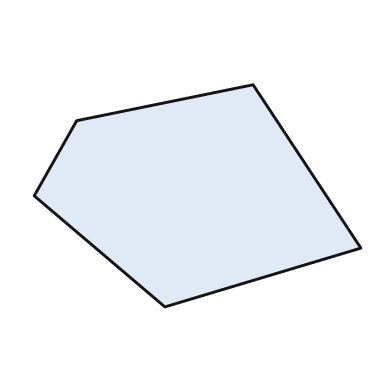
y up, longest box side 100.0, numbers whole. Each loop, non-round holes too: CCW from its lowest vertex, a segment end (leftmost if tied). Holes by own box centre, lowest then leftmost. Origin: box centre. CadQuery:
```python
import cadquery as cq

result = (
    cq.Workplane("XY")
    .moveTo(-10.0, -34.0)
    .lineTo(50.0, -16.0)
    .lineTo(17.0, 34.0)
    .lineTo(-37.0, 23.0)
    .lineTo(-50.0, 0.0)
    .close()
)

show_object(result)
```